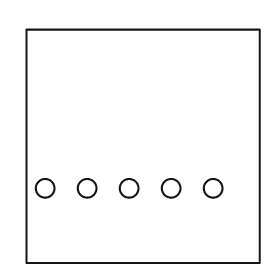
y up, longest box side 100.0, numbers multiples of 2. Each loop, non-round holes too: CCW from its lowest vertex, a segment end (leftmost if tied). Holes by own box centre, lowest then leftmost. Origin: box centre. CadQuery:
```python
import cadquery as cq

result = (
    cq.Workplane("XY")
    .moveTo(-50.0, -50.0)
    .lineTo(50.0, -50.0)
    .lineTo(50.0, 50.0)
    .lineTo(-50.0, 50.0)
    .close()
    .moveTo(-42.0, -18.0)
    .circle(4.0)
    .moveTo(-24.0, -18.0)
    .circle(4.0)
    .moveTo(-6.0, -18.0)
    .circle(4.0)
    .moveTo(12.0, -18.0)
    .circle(4.0)
    .moveTo(30.0, -18.0)
    .circle(4.0)
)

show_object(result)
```